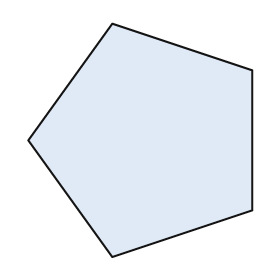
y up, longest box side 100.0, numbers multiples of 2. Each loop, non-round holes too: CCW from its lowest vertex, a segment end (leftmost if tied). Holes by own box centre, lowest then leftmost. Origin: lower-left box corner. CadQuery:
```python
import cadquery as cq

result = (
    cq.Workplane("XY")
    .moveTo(36.0, 0.0)
    .lineTo(96.0, 20.0)
    .lineTo(96.0, 80.0)
    .lineTo(36.0, 100.0)
    .lineTo(0.0, 50.0)
    .close()
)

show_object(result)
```